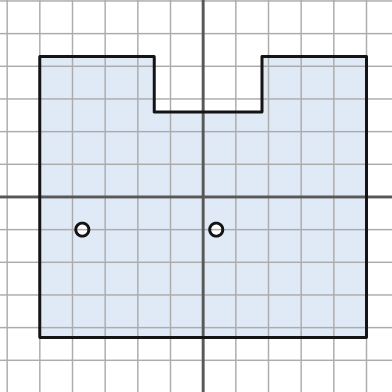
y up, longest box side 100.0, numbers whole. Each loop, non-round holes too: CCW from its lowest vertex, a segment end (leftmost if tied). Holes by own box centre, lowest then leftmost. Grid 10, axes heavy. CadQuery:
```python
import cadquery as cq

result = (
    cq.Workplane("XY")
    .moveTo(-50.0, -43.0)
    .lineTo(50.0, -43.0)
    .lineTo(50.0, 43.0)
    .lineTo(18.0, 43.0)
    .lineTo(18.0, 26.0)
    .lineTo(-15.0, 26.0)
    .lineTo(-15.0, 43.0)
    .lineTo(-50.0, 43.0)
    .close()
    .moveTo(-37.0, -10.0)
    .circle(2.0)
    .moveTo(4.0, -10.0)
    .circle(2.0)
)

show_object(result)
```